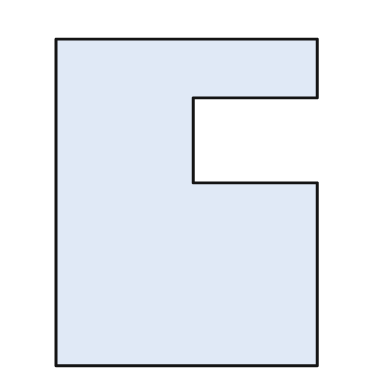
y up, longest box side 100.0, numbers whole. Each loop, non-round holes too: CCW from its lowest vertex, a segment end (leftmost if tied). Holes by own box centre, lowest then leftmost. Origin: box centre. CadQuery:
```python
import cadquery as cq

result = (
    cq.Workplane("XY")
    .moveTo(-40.0, -50.0)
    .lineTo(40.0, -50.0)
    .lineTo(40.0, 6.0)
    .lineTo(2.0, 6.0)
    .lineTo(2.0, 32.0)
    .lineTo(40.0, 32.0)
    .lineTo(40.0, 50.0)
    .lineTo(-40.0, 50.0)
    .close()
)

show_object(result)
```